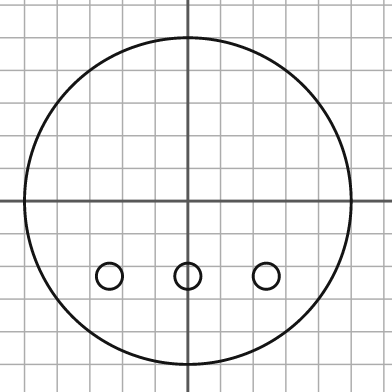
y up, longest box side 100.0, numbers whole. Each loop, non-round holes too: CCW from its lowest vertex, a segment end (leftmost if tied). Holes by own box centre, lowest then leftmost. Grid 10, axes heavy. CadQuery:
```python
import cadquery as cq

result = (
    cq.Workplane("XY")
    .moveTo(0.0, 0.0)
    .circle(50.0)
    .moveTo(-24.0, -23.0)
    .circle(4.0)
    .moveTo(0.0, -23.0)
    .circle(4.0)
    .moveTo(24.0, -23.0)
    .circle(4.0)
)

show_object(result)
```